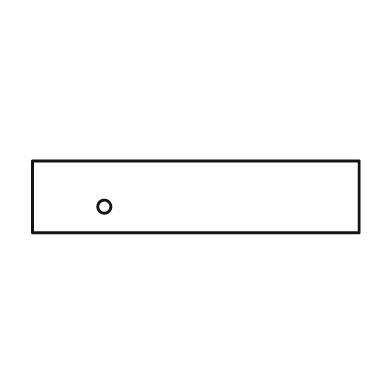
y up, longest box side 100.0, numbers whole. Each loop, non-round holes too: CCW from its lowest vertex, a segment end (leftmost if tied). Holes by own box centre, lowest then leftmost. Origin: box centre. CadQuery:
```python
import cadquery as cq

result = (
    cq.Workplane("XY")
    .moveTo(-50.0, -11.0)
    .lineTo(50.0, -11.0)
    .lineTo(50.0, 11.0)
    .lineTo(-50.0, 11.0)
    .close()
    .moveTo(-28.0, -3.0)
    .circle(2.0)
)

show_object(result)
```